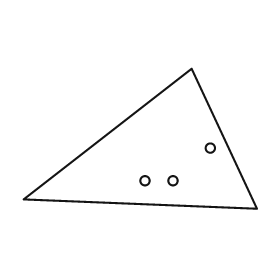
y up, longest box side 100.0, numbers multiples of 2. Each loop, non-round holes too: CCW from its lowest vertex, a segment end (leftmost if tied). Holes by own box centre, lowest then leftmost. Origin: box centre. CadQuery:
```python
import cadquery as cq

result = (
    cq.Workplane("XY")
    .moveTo(50.0, -30.0)
    .lineTo(22.0, 30.0)
    .lineTo(-50.0, -26.0)
    .close()
    .moveTo(2.0, -18.0)
    .circle(2.0)
    .moveTo(14.0, -18.0)
    .circle(2.0)
    .moveTo(30.0, -4.0)
    .circle(2.0)
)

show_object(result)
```